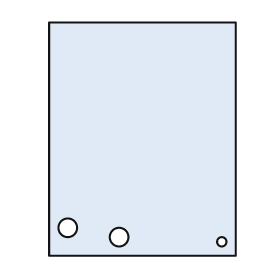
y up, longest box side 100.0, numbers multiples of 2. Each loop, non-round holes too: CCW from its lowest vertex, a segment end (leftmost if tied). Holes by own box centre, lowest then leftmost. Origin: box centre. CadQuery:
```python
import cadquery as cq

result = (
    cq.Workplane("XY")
    .moveTo(-40.0, -50.0)
    .lineTo(40.0, -50.0)
    .lineTo(40.0, 50.0)
    .lineTo(-40.0, 50.0)
    .close()
    .moveTo(34.0, -44.0)
    .circle(2.0)
    .moveTo(-10.0, -42.0)
    .circle(4.0)
    .moveTo(-32.0, -38.0)
    .circle(4.0)
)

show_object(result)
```